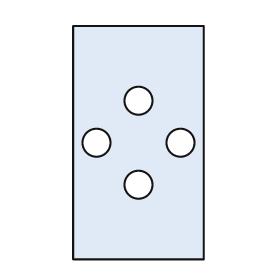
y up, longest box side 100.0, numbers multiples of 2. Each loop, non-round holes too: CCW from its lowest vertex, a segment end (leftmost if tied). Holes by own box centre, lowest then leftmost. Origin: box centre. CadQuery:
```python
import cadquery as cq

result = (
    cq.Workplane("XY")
    .moveTo(-28.0, -50.0)
    .lineTo(28.0, -50.0)
    .lineTo(28.0, 50.0)
    .lineTo(-28.0, 50.0)
    .close()
    .moveTo(0.0, -18.0)
    .circle(6.0)
    .moveTo(-18.0, 0.0)
    .circle(6.0)
    .moveTo(18.0, 0.0)
    .circle(6.0)
    .moveTo(0.0, 18.0)
    .circle(6.0)
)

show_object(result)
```